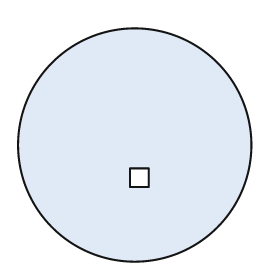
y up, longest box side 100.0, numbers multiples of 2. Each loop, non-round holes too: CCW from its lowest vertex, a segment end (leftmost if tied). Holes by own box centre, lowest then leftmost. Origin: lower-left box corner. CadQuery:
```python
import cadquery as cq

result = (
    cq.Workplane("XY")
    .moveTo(50.0, 50.0)
    .circle(50.0)
    .moveTo(48.0, 32.0)
    .lineTo(56.0, 32.0)
    .lineTo(56.0, 40.0)
    .lineTo(48.0, 40.0)
    .close()
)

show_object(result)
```